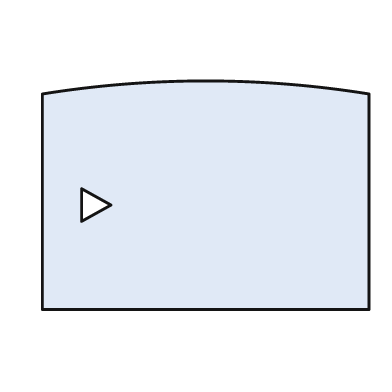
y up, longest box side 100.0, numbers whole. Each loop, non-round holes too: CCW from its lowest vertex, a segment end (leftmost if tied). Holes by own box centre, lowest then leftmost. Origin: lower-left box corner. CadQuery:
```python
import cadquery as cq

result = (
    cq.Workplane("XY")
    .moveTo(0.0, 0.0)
    .lineTo(100.0, 0.0)
    .lineTo(100.0, 66.0)
    .threePointArc((50.0, 70.0), (0.0, 66.0))
    .close()
    .moveTo(12.0, 27.0)
    .lineTo(21.0, 32.0)
    .lineTo(12.0, 37.0)
    .close()
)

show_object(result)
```